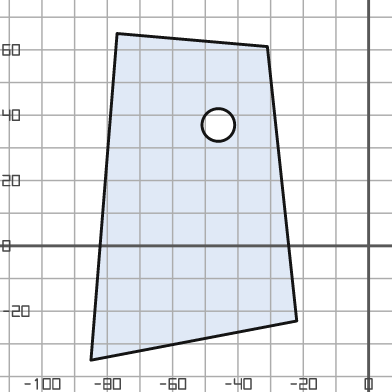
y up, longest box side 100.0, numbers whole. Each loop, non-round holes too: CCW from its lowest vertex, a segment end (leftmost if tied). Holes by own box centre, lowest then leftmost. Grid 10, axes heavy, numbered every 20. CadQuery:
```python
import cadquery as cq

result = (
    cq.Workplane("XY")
    .moveTo(-85.0, -35.0)
    .lineTo(-22.0, -23.0)
    .lineTo(-31.0, 61.0)
    .lineTo(-77.0, 65.0)
    .close()
    .moveTo(-46.0, 37.0)
    .circle(5.0)
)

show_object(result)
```